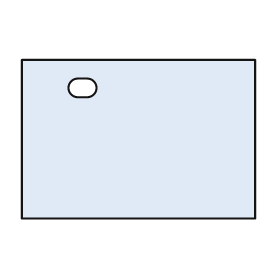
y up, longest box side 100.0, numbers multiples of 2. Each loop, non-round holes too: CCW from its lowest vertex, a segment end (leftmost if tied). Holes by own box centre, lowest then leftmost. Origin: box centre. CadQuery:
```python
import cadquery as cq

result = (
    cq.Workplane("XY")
    .moveTo(-50.0, -34.0)
    .lineTo(50.0, -34.0)
    .lineTo(50.0, 34.0)
    .lineTo(-50.0, 34.0)
    .close()
    .moveTo(-26.0, 18.0)
    .lineTo(-22.0, 18.0)
    .threePointArc((-18.0, 22.0), (-22.0, 26.0))
    .lineTo(-26.0, 26.0)
    .threePointArc((-30.0, 22.0), (-26.0, 18.0))
    .close()
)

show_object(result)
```